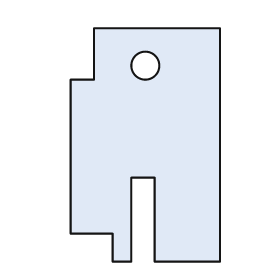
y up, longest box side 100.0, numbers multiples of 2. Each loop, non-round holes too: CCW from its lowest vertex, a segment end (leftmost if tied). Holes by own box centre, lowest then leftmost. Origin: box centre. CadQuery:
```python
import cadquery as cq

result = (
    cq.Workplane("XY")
    .moveTo(-14.0, -50.0)
    .lineTo(-6.0, -50.0)
    .lineTo(-6.0, -14.0)
    .lineTo(4.0, -14.0)
    .lineTo(4.0, -50.0)
    .lineTo(32.0, -50.0)
    .lineTo(32.0, 50.0)
    .lineTo(-22.0, 50.0)
    .lineTo(-22.0, 28.0)
    .lineTo(-32.0, 28.0)
    .lineTo(-32.0, -38.0)
    .lineTo(-14.0, -38.0)
    .close()
    .moveTo(0.0, 34.0)
    .circle(6.0)
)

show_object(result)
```